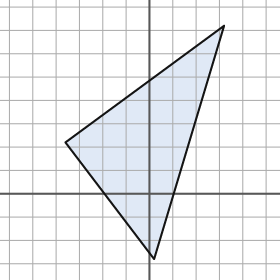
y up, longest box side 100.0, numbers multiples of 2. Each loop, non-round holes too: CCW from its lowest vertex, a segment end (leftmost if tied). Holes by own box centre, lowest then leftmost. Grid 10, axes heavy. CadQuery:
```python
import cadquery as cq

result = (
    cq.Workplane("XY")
    .moveTo(2.0, -28.0)
    .lineTo(32.0, 72.0)
    .lineTo(-36.0, 22.0)
    .close()
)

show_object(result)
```